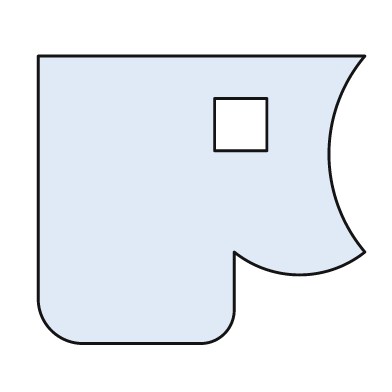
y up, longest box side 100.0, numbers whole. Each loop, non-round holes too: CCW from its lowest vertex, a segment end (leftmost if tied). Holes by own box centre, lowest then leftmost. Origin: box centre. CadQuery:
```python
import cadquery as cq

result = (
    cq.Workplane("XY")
    .moveTo(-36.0, -44.0)
    .lineTo(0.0, -44.0)
    .threePointArc((7.0, -41.0), (10.0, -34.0))
    .lineTo(10.0, -16.0)
    .threePointArc((30.0, -23.0), (50.0, -16.0))
    .threePointArc((39.0, 14.0), (50.0, 44.0))
    .lineTo(-50.0, 44.0)
    .lineTo(-50.0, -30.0)
    .threePointArc((-46.0, -40.0), (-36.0, -44.0))
    .close()
    .moveTo(4.0, 15.0)
    .lineTo(20.0, 15.0)
    .lineTo(20.0, 31.0)
    .lineTo(4.0, 31.0)
    .close()
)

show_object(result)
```